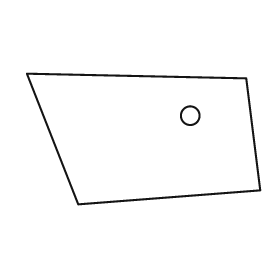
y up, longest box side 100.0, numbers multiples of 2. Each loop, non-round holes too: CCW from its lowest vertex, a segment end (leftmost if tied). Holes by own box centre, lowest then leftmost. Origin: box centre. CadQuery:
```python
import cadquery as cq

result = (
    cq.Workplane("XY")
    .moveTo(-28.0, -28.0)
    .lineTo(50.0, -22.0)
    .lineTo(44.0, 26.0)
    .lineTo(-50.0, 28.0)
    .close()
    .moveTo(20.0, 10.0)
    .circle(4.0)
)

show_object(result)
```